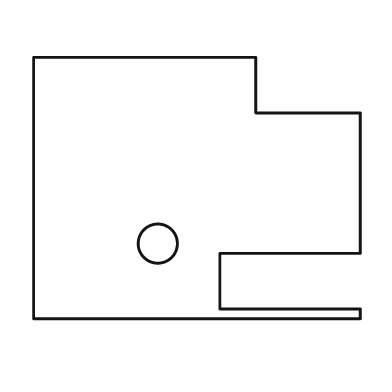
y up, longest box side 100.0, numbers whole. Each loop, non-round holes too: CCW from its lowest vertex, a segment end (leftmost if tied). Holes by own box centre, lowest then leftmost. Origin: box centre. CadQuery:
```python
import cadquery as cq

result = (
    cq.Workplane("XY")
    .moveTo(-50.0, -40.0)
    .lineTo(50.0, -40.0)
    .lineTo(50.0, -37.0)
    .lineTo(7.0, -37.0)
    .lineTo(7.0, -20.0)
    .lineTo(50.0, -20.0)
    .lineTo(50.0, 23.0)
    .lineTo(18.0, 23.0)
    .lineTo(18.0, 40.0)
    .lineTo(-50.0, 40.0)
    .close()
    .moveTo(-12.0, -17.0)
    .circle(6.0)
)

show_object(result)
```